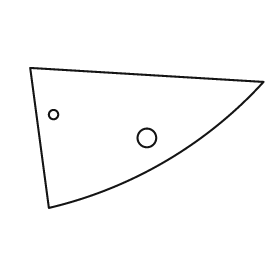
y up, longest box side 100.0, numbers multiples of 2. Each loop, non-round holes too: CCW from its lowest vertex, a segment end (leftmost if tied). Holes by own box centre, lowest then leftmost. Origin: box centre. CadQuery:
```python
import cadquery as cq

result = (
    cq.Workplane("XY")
    .moveTo(-42.0, -30.0)
    .threePointArc((8.0, -10.0), (50.0, 24.0))
    .lineTo(-50.0, 30.0)
    .close()
    .moveTo(0.0, 0.0)
    .circle(4.0)
    .moveTo(-40.0, 10.0)
    .circle(2.0)
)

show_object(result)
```